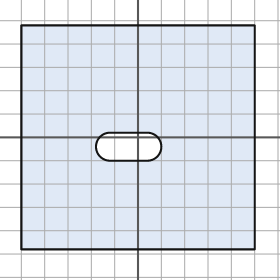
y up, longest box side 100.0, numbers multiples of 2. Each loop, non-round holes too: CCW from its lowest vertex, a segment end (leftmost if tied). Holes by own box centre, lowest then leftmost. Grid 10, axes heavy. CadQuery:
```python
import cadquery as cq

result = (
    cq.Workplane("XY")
    .moveTo(-50.0, -48.0)
    .lineTo(50.0, -48.0)
    .lineTo(50.0, 48.0)
    .lineTo(-50.0, 48.0)
    .close()
    .moveTo(-12.0, -10.0)
    .lineTo(4.0, -10.0)
    .threePointArc((10.0, -4.0), (4.0, 2.0))
    .lineTo(-12.0, 2.0)
    .threePointArc((-18.0, -4.0), (-12.0, -10.0))
    .close()
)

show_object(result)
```